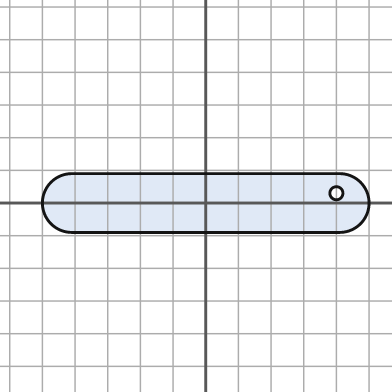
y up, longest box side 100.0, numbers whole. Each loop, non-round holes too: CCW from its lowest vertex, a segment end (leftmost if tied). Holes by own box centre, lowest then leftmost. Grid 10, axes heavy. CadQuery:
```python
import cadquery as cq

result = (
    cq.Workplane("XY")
    .moveTo(-41.0, -9.0)
    .lineTo(41.0, -9.0)
    .threePointArc((50.0, 0.0), (41.0, 9.0))
    .lineTo(-41.0, 9.0)
    .threePointArc((-50.0, 0.0), (-41.0, -9.0))
    .close()
    .moveTo(40.0, 3.0)
    .circle(2.0)
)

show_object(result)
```